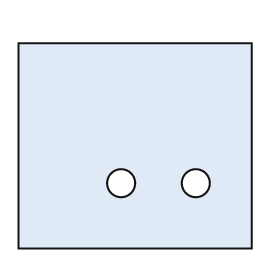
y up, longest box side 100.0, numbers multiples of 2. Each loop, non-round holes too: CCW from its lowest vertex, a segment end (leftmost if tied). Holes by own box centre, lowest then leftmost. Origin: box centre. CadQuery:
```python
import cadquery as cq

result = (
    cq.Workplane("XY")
    .moveTo(-50.0, -44.0)
    .lineTo(50.0, -44.0)
    .lineTo(50.0, 44.0)
    .lineTo(-50.0, 44.0)
    .close()
    .moveTo(-6.0, -16.0)
    .circle(6.0)
    .moveTo(26.0, -16.0)
    .circle(6.0)
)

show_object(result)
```